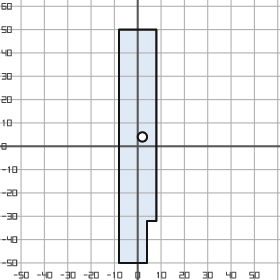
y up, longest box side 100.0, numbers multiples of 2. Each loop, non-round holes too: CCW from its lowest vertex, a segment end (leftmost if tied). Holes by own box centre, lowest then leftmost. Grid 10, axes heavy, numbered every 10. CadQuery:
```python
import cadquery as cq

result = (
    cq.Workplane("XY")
    .moveTo(-8.0, -50.0)
    .lineTo(4.0, -50.0)
    .lineTo(4.0, -32.0)
    .lineTo(8.0, -32.0)
    .lineTo(8.0, 50.0)
    .lineTo(-8.0, 50.0)
    .close()
    .moveTo(2.0, 4.0)
    .circle(2.0)
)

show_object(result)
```